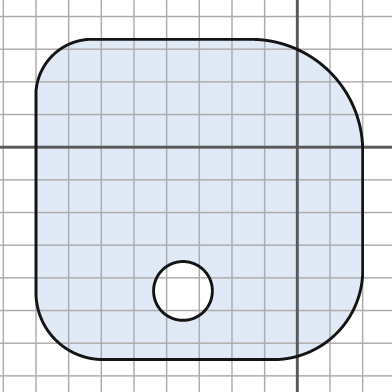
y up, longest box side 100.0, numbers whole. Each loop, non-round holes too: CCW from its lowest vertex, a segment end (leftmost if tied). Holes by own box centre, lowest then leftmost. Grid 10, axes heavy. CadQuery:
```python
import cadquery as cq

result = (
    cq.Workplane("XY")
    .moveTo(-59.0, -65.0)
    .lineTo(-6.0, -65.0)
    .threePointArc((12.0, -57.0), (20.0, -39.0))
    .lineTo(20.0, 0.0)
    .threePointArc((10.0, 23.0), (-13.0, 33.0))
    .lineTo(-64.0, 33.0)
    .threePointArc((-75.0, 28.0), (-80.0, 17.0))
    .lineTo(-80.0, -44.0)
    .threePointArc((-74.0, -59.0), (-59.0, -65.0))
    .close()
    .moveTo(-35.0, -44.0)
    .circle(9.0)
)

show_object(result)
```